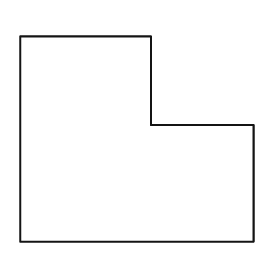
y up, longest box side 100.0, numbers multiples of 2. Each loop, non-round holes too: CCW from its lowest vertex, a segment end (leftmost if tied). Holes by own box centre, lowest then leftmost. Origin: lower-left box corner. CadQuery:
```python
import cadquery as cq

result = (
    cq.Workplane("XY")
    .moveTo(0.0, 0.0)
    .lineTo(100.0, 0.0)
    .lineTo(100.0, 50.0)
    .lineTo(56.0, 50.0)
    .lineTo(56.0, 88.0)
    .lineTo(0.0, 88.0)
    .close()
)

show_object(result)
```